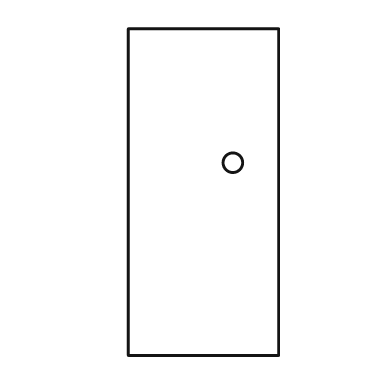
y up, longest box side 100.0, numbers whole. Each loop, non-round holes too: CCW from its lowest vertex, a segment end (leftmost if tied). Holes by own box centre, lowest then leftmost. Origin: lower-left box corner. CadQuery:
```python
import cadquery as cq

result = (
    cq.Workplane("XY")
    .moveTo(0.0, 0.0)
    .lineTo(46.0, 0.0)
    .lineTo(46.0, 100.0)
    .lineTo(0.0, 100.0)
    .close()
    .moveTo(32.0, 59.0)
    .circle(3.0)
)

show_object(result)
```